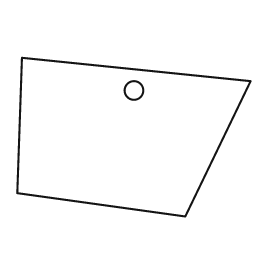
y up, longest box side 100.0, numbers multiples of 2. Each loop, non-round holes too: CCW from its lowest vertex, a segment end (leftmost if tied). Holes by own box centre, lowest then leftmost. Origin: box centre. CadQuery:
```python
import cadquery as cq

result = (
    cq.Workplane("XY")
    .moveTo(22.0, -34.0)
    .lineTo(50.0, 24.0)
    .lineTo(-48.0, 34.0)
    .lineTo(-50.0, -24.0)
    .close()
    .moveTo(0.0, 20.0)
    .circle(4.0)
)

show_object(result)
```